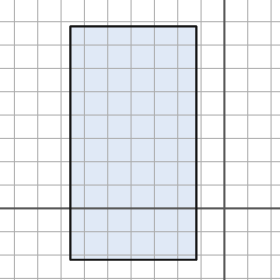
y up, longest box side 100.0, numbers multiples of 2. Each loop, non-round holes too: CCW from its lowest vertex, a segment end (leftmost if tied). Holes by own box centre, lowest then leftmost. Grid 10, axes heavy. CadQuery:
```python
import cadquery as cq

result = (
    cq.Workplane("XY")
    .moveTo(-66.0, -22.0)
    .lineTo(-12.0, -22.0)
    .lineTo(-12.0, 78.0)
    .lineTo(-66.0, 78.0)
    .close()
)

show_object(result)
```